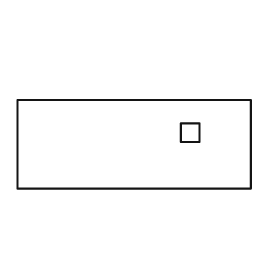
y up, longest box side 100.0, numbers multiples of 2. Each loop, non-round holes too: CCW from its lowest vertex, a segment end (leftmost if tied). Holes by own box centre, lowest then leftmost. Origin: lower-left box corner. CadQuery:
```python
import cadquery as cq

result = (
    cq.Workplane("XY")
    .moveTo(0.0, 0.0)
    .lineTo(100.0, 0.0)
    .lineTo(100.0, 38.0)
    .lineTo(0.0, 38.0)
    .close()
    .moveTo(70.0, 20.0)
    .lineTo(78.0, 20.0)
    .lineTo(78.0, 28.0)
    .lineTo(70.0, 28.0)
    .close()
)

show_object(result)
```